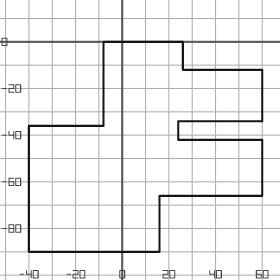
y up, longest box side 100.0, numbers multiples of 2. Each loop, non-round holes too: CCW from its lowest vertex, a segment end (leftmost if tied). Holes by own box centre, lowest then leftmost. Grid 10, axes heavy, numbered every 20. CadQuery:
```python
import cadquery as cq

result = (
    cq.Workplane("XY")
    .moveTo(-40.0, -90.0)
    .lineTo(16.0, -90.0)
    .lineTo(16.0, -66.0)
    .lineTo(60.0, -66.0)
    .lineTo(60.0, -42.0)
    .lineTo(24.0, -42.0)
    .lineTo(24.0, -34.0)
    .lineTo(60.0, -34.0)
    .lineTo(60.0, -12.0)
    .lineTo(26.0, -12.0)
    .lineTo(26.0, 0.0)
    .lineTo(-8.0, 0.0)
    .lineTo(-8.0, -36.0)
    .lineTo(-40.0, -36.0)
    .close()
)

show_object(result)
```